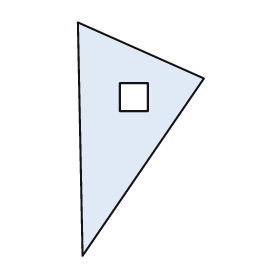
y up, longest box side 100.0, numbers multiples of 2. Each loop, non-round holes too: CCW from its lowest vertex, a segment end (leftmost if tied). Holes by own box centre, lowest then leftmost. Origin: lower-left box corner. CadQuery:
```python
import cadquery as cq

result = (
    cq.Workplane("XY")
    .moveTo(2.0, 0.0)
    .lineTo(54.0, 76.0)
    .lineTo(0.0, 100.0)
    .close()
    .moveTo(18.0, 62.0)
    .lineTo(30.0, 62.0)
    .lineTo(30.0, 74.0)
    .lineTo(18.0, 74.0)
    .close()
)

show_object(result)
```